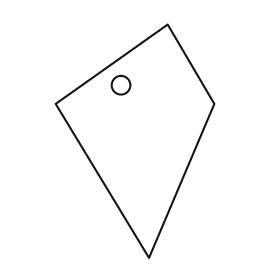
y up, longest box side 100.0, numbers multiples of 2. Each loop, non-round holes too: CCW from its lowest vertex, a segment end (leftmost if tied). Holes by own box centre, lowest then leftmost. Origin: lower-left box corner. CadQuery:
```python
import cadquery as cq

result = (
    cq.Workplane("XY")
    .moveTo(40.0, 0.0)
    .lineTo(68.0, 66.0)
    .lineTo(48.0, 100.0)
    .lineTo(0.0, 66.0)
    .close()
    .moveTo(28.0, 74.0)
    .circle(4.0)
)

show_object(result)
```